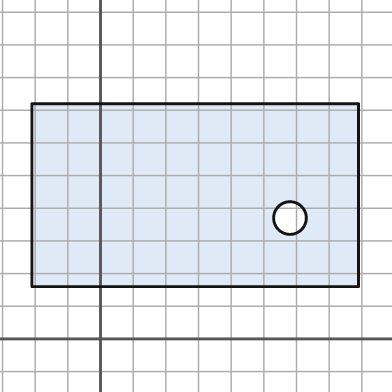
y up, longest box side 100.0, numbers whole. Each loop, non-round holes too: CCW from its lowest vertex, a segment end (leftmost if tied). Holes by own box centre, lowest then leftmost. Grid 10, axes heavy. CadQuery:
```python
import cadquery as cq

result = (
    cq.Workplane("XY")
    .moveTo(-21.0, 16.0)
    .lineTo(79.0, 16.0)
    .lineTo(79.0, 72.0)
    .lineTo(-21.0, 72.0)
    .close()
    .moveTo(58.0, 37.0)
    .circle(5.0)
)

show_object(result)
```